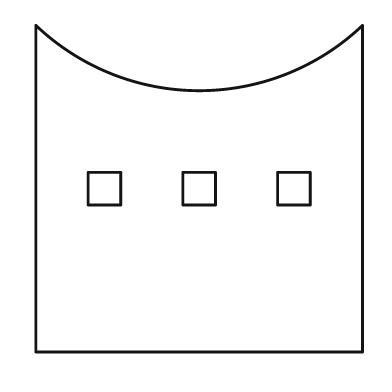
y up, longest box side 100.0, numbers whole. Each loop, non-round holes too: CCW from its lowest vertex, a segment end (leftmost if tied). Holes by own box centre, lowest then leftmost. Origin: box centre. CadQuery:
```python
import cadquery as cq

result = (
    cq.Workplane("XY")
    .moveTo(-50.0, -50.0)
    .lineTo(50.0, -50.0)
    .lineTo(50.0, 50.0)
    .threePointArc((0.0, 30.0), (-50.0, 50.0))
    .close()
    .moveTo(-34.0, -5.0)
    .lineTo(-24.0, -5.0)
    .lineTo(-24.0, 5.0)
    .lineTo(-34.0, 5.0)
    .close()
    .moveTo(-5.0, -5.0)
    .lineTo(5.0, -5.0)
    .lineTo(5.0, 5.0)
    .lineTo(-5.0, 5.0)
    .close()
    .moveTo(24.0, -5.0)
    .lineTo(34.0, -5.0)
    .lineTo(34.0, 5.0)
    .lineTo(24.0, 5.0)
    .close()
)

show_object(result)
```